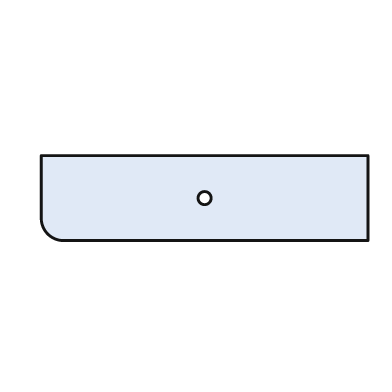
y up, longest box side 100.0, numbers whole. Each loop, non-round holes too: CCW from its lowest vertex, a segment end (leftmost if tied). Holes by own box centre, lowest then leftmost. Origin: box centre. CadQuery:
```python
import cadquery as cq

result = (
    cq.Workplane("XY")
    .moveTo(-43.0, -13.0)
    .lineTo(50.0, -13.0)
    .lineTo(50.0, 13.0)
    .lineTo(-50.0, 13.0)
    .lineTo(-50.0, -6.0)
    .threePointArc((-48.0, -11.0), (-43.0, -13.0))
    .close()
    .moveTo(0.0, 0.0)
    .circle(2.0)
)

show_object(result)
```